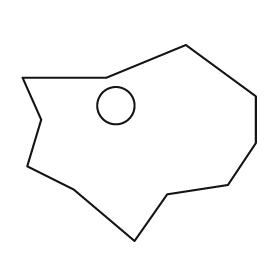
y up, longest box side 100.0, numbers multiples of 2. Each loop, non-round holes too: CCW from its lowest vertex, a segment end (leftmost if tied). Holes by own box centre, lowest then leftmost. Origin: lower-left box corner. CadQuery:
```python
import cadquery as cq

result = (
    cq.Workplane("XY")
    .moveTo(48.0, 0.0)
    .lineTo(62.0, 20.0)
    .lineTo(88.0, 24.0)
    .lineTo(100.0, 42.0)
    .lineTo(100.0, 62.0)
    .lineTo(70.0, 84.0)
    .lineTo(36.0, 70.0)
    .lineTo(0.0, 70.0)
    .lineTo(8.0, 52.0)
    .lineTo(2.0, 32.0)
    .lineTo(22.0, 22.0)
    .close()
    .moveTo(40.0, 58.0)
    .circle(8.0)
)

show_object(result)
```